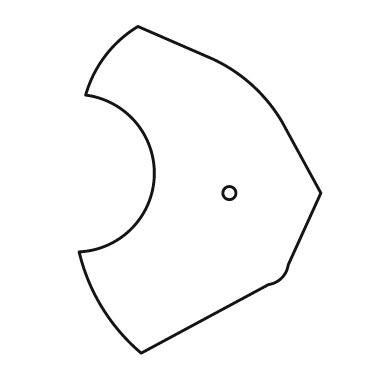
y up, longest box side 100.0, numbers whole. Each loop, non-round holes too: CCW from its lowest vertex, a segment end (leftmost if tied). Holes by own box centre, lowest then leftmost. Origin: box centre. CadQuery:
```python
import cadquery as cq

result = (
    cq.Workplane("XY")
    .moveTo(-18.0, -50.0)
    .lineTo(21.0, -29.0)
    .threePointArc((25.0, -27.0), (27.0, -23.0))
    .lineTo(37.0, -1.0)
    .lineTo(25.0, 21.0)
    .threePointArc((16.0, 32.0), (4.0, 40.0))
    .lineTo(-19.0, 50.0)
    .threePointArc((-29.0, 41.0), (-35.0, 29.0))
    .threePointArc((-14.0, 4.0), (-37.0, -19.0))
    .threePointArc((-30.0, -36.0), (-18.0, -50.0))
    .close()
    .moveTo(9.0, -1.0)
    .circle(2.0)
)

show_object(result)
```